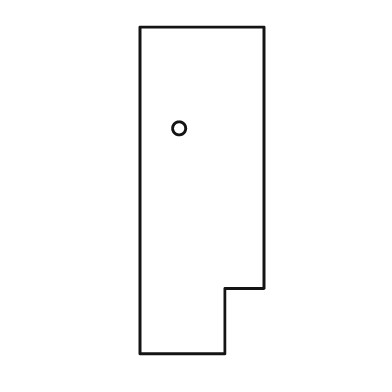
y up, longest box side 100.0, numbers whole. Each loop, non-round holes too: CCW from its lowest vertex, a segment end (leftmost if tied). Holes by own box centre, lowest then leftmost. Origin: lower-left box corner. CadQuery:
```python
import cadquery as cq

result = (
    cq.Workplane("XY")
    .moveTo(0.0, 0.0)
    .lineTo(26.0, 0.0)
    .lineTo(26.0, 20.0)
    .lineTo(38.0, 20.0)
    .lineTo(38.0, 100.0)
    .lineTo(0.0, 100.0)
    .close()
    .moveTo(12.0, 69.0)
    .circle(2.0)
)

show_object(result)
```